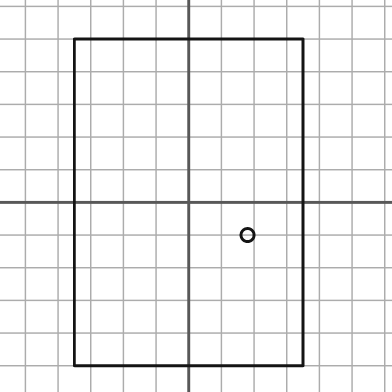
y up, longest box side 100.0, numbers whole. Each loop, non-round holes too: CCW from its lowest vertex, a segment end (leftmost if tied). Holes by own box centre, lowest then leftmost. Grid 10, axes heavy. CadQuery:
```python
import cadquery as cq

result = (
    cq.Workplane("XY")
    .moveTo(-35.0, -50.0)
    .lineTo(35.0, -50.0)
    .lineTo(35.0, 50.0)
    .lineTo(-35.0, 50.0)
    .close()
    .moveTo(18.0, -10.0)
    .circle(2.0)
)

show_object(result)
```